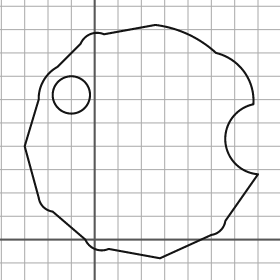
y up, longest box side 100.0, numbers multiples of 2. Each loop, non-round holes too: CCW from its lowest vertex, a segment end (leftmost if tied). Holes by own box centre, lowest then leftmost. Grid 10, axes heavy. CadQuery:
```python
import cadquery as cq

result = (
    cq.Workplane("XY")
    .moveTo(28.0, -8.0)
    .lineTo(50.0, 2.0)
    .threePointArc((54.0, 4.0), (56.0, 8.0))
    .lineTo(70.0, 28.0)
    .threePointArc((56.0, 42.0), (68.0, 58.0))
    .threePointArc((64.0, 72.0), (52.0, 80.0))
    .threePointArc((40.0, 88.0), (26.0, 92.0))
    .lineTo(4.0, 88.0)
    .threePointArc((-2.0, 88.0), (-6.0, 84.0))
    .lineTo(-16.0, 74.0)
    .threePointArc((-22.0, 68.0), (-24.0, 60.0))
    .lineTo(-30.0, 40.0)
    .lineTo(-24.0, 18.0)
    .threePointArc((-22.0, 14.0), (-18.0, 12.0))
    .lineTo(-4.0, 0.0)
    .threePointArc((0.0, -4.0), (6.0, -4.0))
    .close()
    .moveTo(-10.0, 62.0)
    .circle(8.0)
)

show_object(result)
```